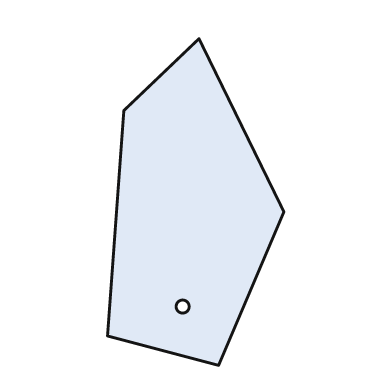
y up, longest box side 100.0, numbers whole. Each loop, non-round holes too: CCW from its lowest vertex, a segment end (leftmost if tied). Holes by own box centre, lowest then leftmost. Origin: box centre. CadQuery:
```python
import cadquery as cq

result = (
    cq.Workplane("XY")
    .moveTo(7.0, -50.0)
    .lineTo(27.0, -3.0)
    .lineTo(1.0, 50.0)
    .lineTo(-22.0, 28.0)
    .lineTo(-27.0, -41.0)
    .close()
    .moveTo(-4.0, -32.0)
    .circle(2.0)
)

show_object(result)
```